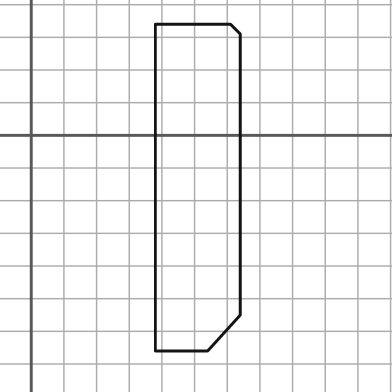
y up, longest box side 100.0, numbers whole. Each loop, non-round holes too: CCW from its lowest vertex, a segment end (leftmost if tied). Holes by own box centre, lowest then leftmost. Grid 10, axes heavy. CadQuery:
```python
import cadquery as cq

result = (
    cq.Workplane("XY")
    .moveTo(38.0, -66.0)
    .lineTo(54.0, -66.0)
    .lineTo(64.0, -55.0)
    .lineTo(64.0, 31.0)
    .lineTo(61.0, 34.0)
    .lineTo(38.0, 34.0)
    .close()
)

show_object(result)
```